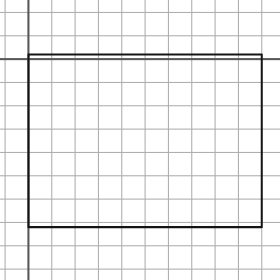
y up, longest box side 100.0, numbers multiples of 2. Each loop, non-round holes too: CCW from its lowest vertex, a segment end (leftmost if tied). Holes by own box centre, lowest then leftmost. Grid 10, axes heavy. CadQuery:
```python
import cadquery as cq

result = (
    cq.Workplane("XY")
    .moveTo(0.0, -72.0)
    .lineTo(100.0, -72.0)
    .lineTo(100.0, 2.0)
    .lineTo(0.0, 2.0)
    .close()
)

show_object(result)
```